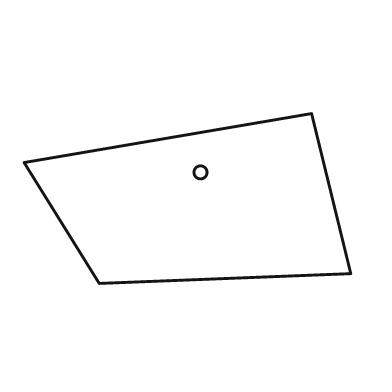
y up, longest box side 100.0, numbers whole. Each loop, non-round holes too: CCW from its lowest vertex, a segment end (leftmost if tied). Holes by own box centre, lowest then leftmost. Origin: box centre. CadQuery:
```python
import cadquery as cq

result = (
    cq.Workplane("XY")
    .moveTo(-27.0, -26.0)
    .lineTo(50.0, -23.0)
    .lineTo(38.0, 26.0)
    .lineTo(-50.0, 11.0)
    .close()
    .moveTo(4.0, 8.0)
    .circle(2.0)
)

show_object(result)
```